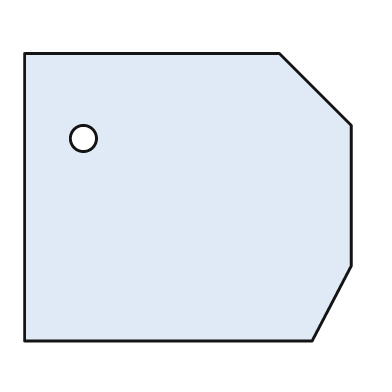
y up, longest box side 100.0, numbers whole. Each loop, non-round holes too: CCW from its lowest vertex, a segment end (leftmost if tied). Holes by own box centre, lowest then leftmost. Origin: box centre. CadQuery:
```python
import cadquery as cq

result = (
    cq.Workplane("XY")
    .moveTo(-50.0, -44.0)
    .lineTo(38.0, -44.0)
    .lineTo(50.0, -21.0)
    .lineTo(50.0, 22.0)
    .lineTo(28.0, 44.0)
    .lineTo(-50.0, 44.0)
    .close()
    .moveTo(-32.0, 18.0)
    .circle(4.0)
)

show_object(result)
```